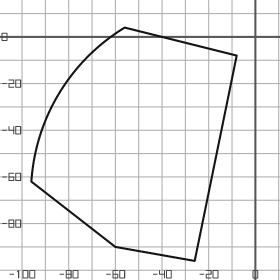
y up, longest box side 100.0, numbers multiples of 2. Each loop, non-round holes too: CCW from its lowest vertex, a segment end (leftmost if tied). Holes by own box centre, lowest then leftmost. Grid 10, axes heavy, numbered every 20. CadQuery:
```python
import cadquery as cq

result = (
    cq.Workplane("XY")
    .moveTo(-26.0, -96.0)
    .lineTo(-8.0, -8.0)
    .lineTo(-56.0, 4.0)
    .threePointArc((-84.0, -24.0), (-96.0, -62.0))
    .lineTo(-60.0, -90.0)
    .close()
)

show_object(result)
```